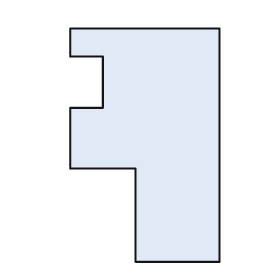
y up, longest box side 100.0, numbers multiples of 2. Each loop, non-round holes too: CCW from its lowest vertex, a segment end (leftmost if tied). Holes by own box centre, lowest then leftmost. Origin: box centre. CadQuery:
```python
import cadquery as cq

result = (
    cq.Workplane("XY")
    .moveTo(-4.0, -50.0)
    .lineTo(32.0, -50.0)
    .lineTo(32.0, 50.0)
    .lineTo(-32.0, 50.0)
    .lineTo(-32.0, 38.0)
    .lineTo(-18.0, 38.0)
    .lineTo(-18.0, 16.0)
    .lineTo(-32.0, 16.0)
    .lineTo(-32.0, -10.0)
    .lineTo(-4.0, -10.0)
    .close()
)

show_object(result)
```